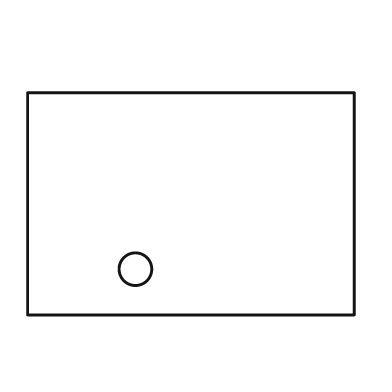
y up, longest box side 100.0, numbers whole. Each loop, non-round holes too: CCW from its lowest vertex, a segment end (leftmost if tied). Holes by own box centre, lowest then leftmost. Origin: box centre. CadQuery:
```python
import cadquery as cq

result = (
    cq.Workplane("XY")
    .moveTo(-50.0, -34.0)
    .lineTo(50.0, -34.0)
    .lineTo(50.0, 34.0)
    .lineTo(-50.0, 34.0)
    .close()
    .moveTo(-17.0, -20.0)
    .circle(5.0)
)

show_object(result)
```